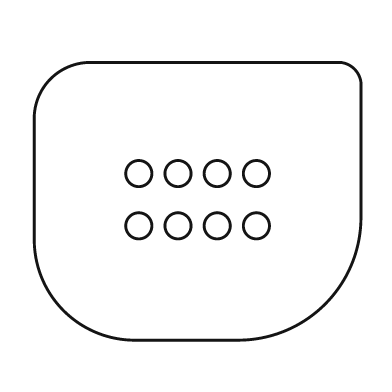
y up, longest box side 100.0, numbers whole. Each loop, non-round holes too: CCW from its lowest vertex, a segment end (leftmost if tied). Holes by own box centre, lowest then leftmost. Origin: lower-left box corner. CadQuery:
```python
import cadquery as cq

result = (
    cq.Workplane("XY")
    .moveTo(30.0, 0.0)
    .lineTo(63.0, 0.0)
    .threePointArc((89.0, 11.0), (100.0, 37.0))
    .lineTo(100.0, 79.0)
    .threePointArc((98.0, 83.0), (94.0, 85.0))
    .lineTo(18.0, 85.0)
    .threePointArc((5.0, 80.0), (0.0, 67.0))
    .lineTo(0.0, 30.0)
    .threePointArc((9.0, 9.0), (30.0, 0.0))
    .close()
    .moveTo(32.0, 35.0)
    .circle(4.0)
    .moveTo(44.0, 35.0)
    .circle(4.0)
    .moveTo(56.0, 35.0)
    .circle(4.0)
    .moveTo(68.0, 35.0)
    .circle(4.0)
    .moveTo(32.0, 51.0)
    .circle(4.0)
    .moveTo(44.0, 51.0)
    .circle(4.0)
    .moveTo(56.0, 51.0)
    .circle(4.0)
    .moveTo(68.0, 51.0)
    .circle(4.0)
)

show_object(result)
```